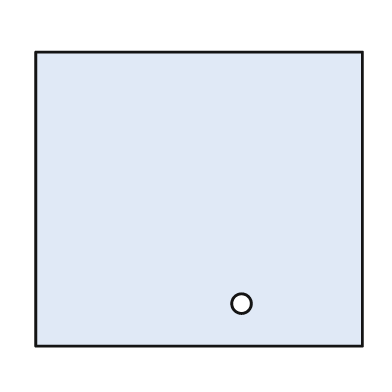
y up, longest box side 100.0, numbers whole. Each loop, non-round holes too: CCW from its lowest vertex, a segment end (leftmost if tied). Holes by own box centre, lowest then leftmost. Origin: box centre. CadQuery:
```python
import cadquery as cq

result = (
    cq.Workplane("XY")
    .moveTo(-50.0, -45.0)
    .lineTo(50.0, -45.0)
    .lineTo(50.0, 45.0)
    .lineTo(-50.0, 45.0)
    .close()
    .moveTo(13.0, -32.0)
    .circle(3.0)
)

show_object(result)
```